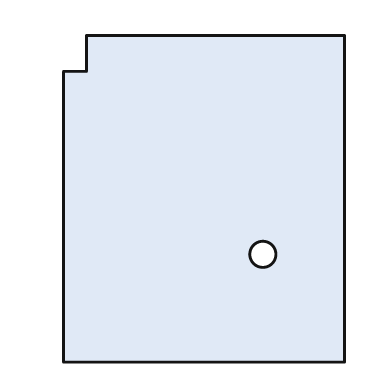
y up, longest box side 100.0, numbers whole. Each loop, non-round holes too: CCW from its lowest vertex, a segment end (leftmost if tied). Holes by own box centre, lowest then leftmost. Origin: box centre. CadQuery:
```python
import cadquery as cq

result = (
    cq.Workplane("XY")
    .moveTo(-43.0, -50.0)
    .lineTo(43.0, -50.0)
    .lineTo(43.0, 50.0)
    .lineTo(-36.0, 50.0)
    .lineTo(-36.0, 39.0)
    .lineTo(-43.0, 39.0)
    .close()
    .moveTo(18.0, -17.0)
    .circle(4.0)
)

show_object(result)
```